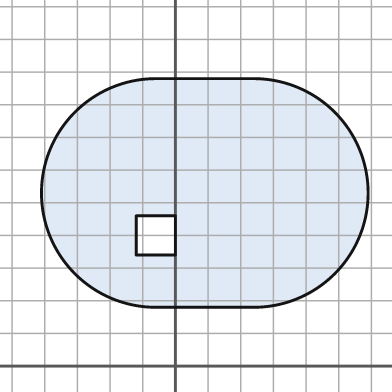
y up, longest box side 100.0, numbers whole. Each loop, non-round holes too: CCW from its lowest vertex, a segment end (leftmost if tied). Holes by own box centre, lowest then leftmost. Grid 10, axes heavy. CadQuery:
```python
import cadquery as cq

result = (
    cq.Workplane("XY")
    .moveTo(-6.0, 18.0)
    .lineTo(24.0, 18.0)
    .threePointArc((59.0, 53.0), (24.0, 88.0))
    .lineTo(-6.0, 88.0)
    .threePointArc((-41.0, 53.0), (-6.0, 18.0))
    .close()
    .moveTo(-12.0, 34.0)
    .lineTo(0.0, 34.0)
    .lineTo(0.0, 46.0)
    .lineTo(-12.0, 46.0)
    .close()
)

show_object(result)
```